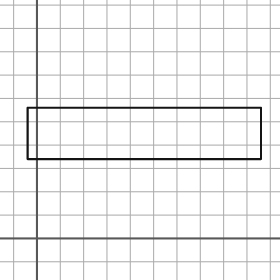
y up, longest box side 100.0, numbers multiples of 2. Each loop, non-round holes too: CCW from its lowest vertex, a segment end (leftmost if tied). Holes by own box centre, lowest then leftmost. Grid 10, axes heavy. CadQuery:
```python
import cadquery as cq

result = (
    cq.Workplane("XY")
    .moveTo(-4.0, 34.0)
    .lineTo(96.0, 34.0)
    .lineTo(96.0, 56.0)
    .lineTo(-4.0, 56.0)
    .close()
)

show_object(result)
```